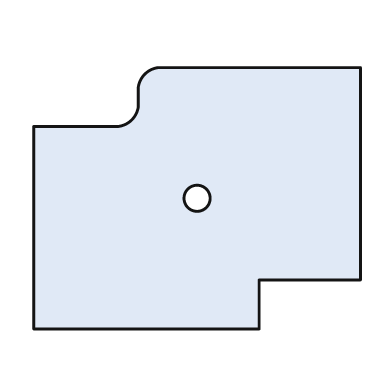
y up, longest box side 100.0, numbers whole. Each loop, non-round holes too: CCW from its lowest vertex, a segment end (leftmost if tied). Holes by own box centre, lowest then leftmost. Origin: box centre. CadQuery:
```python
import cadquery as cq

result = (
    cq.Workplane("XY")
    .moveTo(-50.0, -40.0)
    .lineTo(19.0, -40.0)
    .lineTo(19.0, -25.0)
    .lineTo(50.0, -25.0)
    .lineTo(50.0, 40.0)
    .lineTo(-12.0, 40.0)
    .threePointArc((-16.0, 38.0), (-18.0, 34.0))
    .lineTo(-18.0, 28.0)
    .threePointArc((-20.0, 24.0), (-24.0, 22.0))
    .lineTo(-50.0, 22.0)
    .close()
    .moveTo(0.0, 0.0)
    .circle(4.0)
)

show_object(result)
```